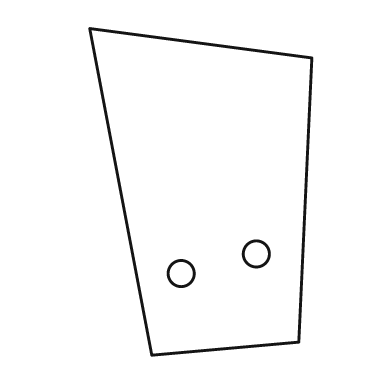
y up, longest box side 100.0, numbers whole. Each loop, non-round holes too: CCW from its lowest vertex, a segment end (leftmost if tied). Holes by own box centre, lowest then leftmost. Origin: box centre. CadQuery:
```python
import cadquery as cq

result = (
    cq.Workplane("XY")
    .moveTo(-15.0, -50.0)
    .lineTo(30.0, -46.0)
    .lineTo(34.0, 41.0)
    .lineTo(-34.0, 50.0)
    .close()
    .moveTo(-6.0, -25.0)
    .circle(4.0)
    .moveTo(17.0, -19.0)
    .circle(4.0)
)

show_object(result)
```